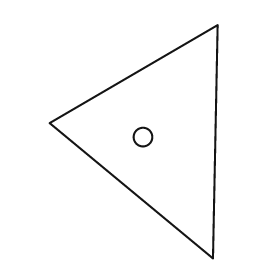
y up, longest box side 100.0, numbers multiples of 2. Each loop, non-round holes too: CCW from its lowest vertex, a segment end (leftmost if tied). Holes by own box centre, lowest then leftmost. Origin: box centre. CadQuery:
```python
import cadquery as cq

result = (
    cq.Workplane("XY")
    .moveTo(34.0, -50.0)
    .lineTo(36.0, 50.0)
    .lineTo(-36.0, 8.0)
    .close()
    .moveTo(4.0, 2.0)
    .circle(4.0)
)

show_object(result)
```